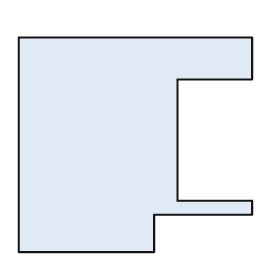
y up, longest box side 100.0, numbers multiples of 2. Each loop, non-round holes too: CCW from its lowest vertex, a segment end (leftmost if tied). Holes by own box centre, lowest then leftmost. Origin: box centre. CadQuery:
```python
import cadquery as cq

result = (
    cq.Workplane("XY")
    .moveTo(-50.0, -46.0)
    .lineTo(8.0, -46.0)
    .lineTo(8.0, -30.0)
    .lineTo(50.0, -30.0)
    .lineTo(50.0, -24.0)
    .lineTo(18.0, -24.0)
    .lineTo(18.0, 28.0)
    .lineTo(50.0, 28.0)
    .lineTo(50.0, 46.0)
    .lineTo(-50.0, 46.0)
    .close()
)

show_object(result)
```